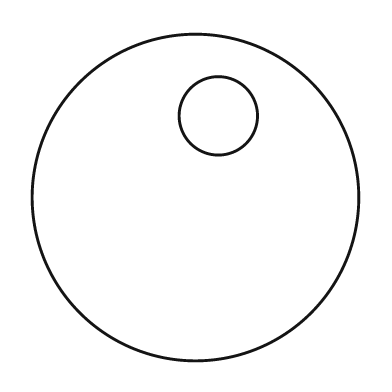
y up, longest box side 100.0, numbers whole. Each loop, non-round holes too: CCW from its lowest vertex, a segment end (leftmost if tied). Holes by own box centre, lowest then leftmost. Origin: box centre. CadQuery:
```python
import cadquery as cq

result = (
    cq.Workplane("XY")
    .moveTo(0.0, 0.0)
    .circle(50.0)
    .moveTo(7.0, 25.0)
    .circle(12.0)
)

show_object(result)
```